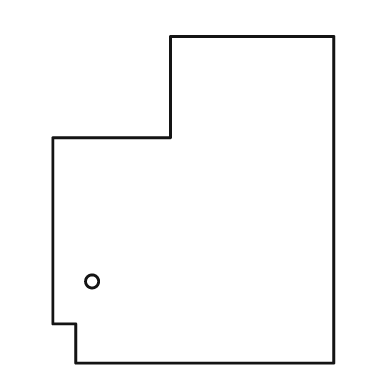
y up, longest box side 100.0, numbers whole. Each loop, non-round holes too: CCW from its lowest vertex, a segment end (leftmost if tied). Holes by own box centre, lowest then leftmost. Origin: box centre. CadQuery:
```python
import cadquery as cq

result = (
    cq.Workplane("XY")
    .moveTo(-36.0, -50.0)
    .lineTo(43.0, -50.0)
    .lineTo(43.0, 50.0)
    .lineTo(-7.0, 50.0)
    .lineTo(-7.0, 19.0)
    .lineTo(-43.0, 19.0)
    .lineTo(-43.0, -38.0)
    .lineTo(-36.0, -38.0)
    .close()
    .moveTo(-31.0, -25.0)
    .circle(2.0)
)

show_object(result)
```